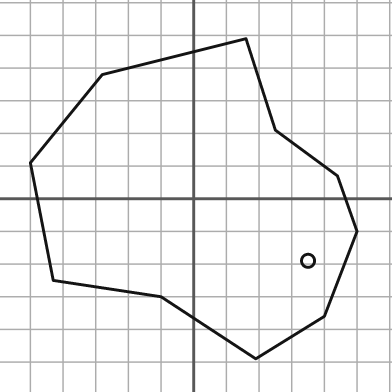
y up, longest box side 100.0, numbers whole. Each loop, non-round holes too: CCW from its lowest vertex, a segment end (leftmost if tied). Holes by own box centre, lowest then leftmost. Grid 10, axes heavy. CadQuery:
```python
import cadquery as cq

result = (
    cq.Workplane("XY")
    .moveTo(19.0, -49.0)
    .lineTo(40.0, -36.0)
    .lineTo(50.0, -10.0)
    .lineTo(44.0, 7.0)
    .lineTo(25.0, 21.0)
    .lineTo(16.0, 49.0)
    .lineTo(-28.0, 38.0)
    .lineTo(-50.0, 11.0)
    .lineTo(-43.0, -25.0)
    .lineTo(-10.0, -30.0)
    .close()
    .moveTo(35.0, -19.0)
    .circle(2.0)
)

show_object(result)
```